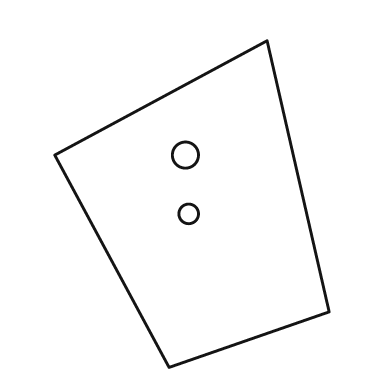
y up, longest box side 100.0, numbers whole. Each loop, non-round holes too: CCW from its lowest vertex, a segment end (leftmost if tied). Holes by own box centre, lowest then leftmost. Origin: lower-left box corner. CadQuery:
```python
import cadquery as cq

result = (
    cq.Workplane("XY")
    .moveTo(35.0, 0.0)
    .lineTo(84.0, 17.0)
    .lineTo(65.0, 100.0)
    .lineTo(0.0, 65.0)
    .close()
    .moveTo(41.0, 47.0)
    .circle(3.0)
    .moveTo(40.0, 65.0)
    .circle(4.0)
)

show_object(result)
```